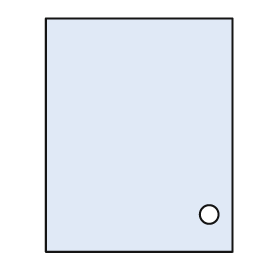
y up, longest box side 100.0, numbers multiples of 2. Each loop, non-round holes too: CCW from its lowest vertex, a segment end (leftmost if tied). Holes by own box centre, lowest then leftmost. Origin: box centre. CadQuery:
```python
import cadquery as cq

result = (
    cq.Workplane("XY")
    .moveTo(-40.0, -50.0)
    .lineTo(40.0, -50.0)
    .lineTo(40.0, 50.0)
    .lineTo(-40.0, 50.0)
    .close()
    .moveTo(30.0, -34.0)
    .circle(4.0)
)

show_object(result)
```